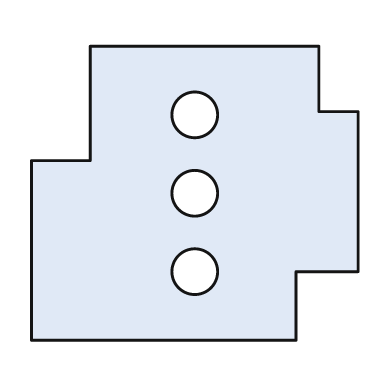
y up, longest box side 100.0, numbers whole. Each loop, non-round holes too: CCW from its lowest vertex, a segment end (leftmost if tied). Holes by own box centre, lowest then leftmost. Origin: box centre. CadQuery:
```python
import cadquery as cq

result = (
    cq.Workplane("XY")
    .moveTo(-50.0, -45.0)
    .lineTo(31.0, -45.0)
    .lineTo(31.0, -24.0)
    .lineTo(50.0, -24.0)
    .lineTo(50.0, 25.0)
    .lineTo(38.0, 25.0)
    .lineTo(38.0, 45.0)
    .lineTo(-32.0, 45.0)
    .lineTo(-32.0, 10.0)
    .lineTo(-50.0, 10.0)
    .close()
    .moveTo(0.0, -24.0)
    .circle(7.0)
    .moveTo(0.0, 0.0)
    .circle(7.0)
    .moveTo(0.0, 24.0)
    .circle(7.0)
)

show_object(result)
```